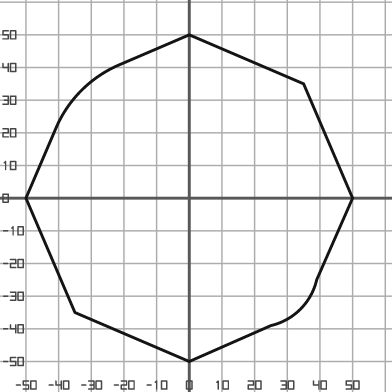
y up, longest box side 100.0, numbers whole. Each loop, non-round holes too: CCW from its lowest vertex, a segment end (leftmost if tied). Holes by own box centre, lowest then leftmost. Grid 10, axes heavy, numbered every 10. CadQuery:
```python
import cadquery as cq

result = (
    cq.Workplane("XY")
    .moveTo(0.0, -50.0)
    .lineTo(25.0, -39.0)
    .threePointArc((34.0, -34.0), (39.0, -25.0))
    .lineTo(50.0, 0.0)
    .lineTo(35.0, 35.0)
    .lineTo(0.0, 50.0)
    .lineTo(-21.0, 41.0)
    .threePointArc((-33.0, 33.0), (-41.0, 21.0))
    .lineTo(-50.0, 0.0)
    .lineTo(-35.0, -35.0)
    .close()
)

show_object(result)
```